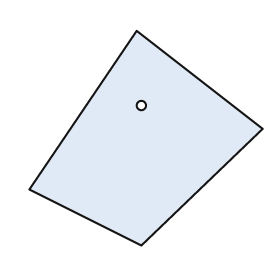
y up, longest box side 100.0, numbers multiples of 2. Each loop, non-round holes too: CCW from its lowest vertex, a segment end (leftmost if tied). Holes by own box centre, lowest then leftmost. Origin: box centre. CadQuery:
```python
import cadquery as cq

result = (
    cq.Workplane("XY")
    .moveTo(-2.0, -46.0)
    .lineTo(50.0, 4.0)
    .lineTo(-4.0, 46.0)
    .lineTo(-50.0, -22.0)
    .close()
    .moveTo(-2.0, 14.0)
    .circle(2.0)
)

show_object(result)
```